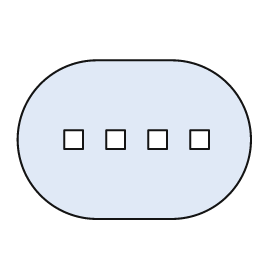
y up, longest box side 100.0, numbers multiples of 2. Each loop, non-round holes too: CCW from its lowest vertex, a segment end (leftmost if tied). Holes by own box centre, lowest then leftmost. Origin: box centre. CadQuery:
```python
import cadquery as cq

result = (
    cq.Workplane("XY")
    .moveTo(-16.0, -34.0)
    .lineTo(16.0, -34.0)
    .threePointArc((50.0, 0.0), (16.0, 34.0))
    .lineTo(-16.0, 34.0)
    .threePointArc((-50.0, 0.0), (-16.0, -34.0))
    .close()
    .moveTo(-30.0, -4.0)
    .lineTo(-22.0, -4.0)
    .lineTo(-22.0, 4.0)
    .lineTo(-30.0, 4.0)
    .close()
    .moveTo(-12.0, -4.0)
    .lineTo(-4.0, -4.0)
    .lineTo(-4.0, 4.0)
    .lineTo(-12.0, 4.0)
    .close()
    .moveTo(6.0, -4.0)
    .lineTo(14.0, -4.0)
    .lineTo(14.0, 4.0)
    .lineTo(6.0, 4.0)
    .close()
    .moveTo(24.0, -4.0)
    .lineTo(32.0, -4.0)
    .lineTo(32.0, 4.0)
    .lineTo(24.0, 4.0)
    .close()
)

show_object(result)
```